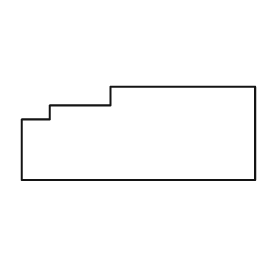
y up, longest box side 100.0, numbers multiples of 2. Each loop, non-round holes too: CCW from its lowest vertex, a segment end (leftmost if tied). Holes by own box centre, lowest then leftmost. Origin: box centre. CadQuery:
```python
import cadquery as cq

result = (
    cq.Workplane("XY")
    .moveTo(-50.0, -20.0)
    .lineTo(50.0, -20.0)
    .lineTo(50.0, 20.0)
    .lineTo(-12.0, 20.0)
    .lineTo(-12.0, 12.0)
    .lineTo(-38.0, 12.0)
    .lineTo(-38.0, 6.0)
    .lineTo(-50.0, 6.0)
    .close()
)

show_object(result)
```